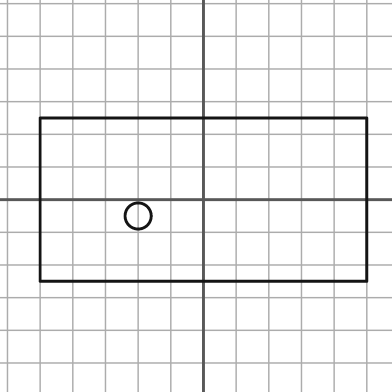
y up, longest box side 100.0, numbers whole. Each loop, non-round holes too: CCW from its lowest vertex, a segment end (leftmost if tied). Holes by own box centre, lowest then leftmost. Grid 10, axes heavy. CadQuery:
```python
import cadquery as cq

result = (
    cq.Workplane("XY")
    .moveTo(-50.0, -25.0)
    .lineTo(50.0, -25.0)
    .lineTo(50.0, 25.0)
    .lineTo(-50.0, 25.0)
    .close()
    .moveTo(-20.0, -5.0)
    .circle(4.0)
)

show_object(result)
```